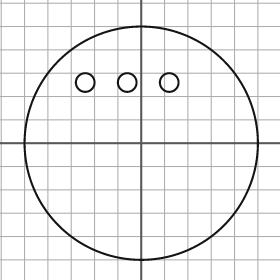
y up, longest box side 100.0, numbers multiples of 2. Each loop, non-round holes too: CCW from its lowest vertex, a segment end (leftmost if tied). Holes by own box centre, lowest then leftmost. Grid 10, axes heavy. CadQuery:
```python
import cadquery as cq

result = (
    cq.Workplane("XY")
    .moveTo(0.0, 0.0)
    .circle(50.0)
    .moveTo(-24.0, 26.0)
    .circle(4.0)
    .moveTo(-6.0, 26.0)
    .circle(4.0)
    .moveTo(12.0, 26.0)
    .circle(4.0)
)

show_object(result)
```